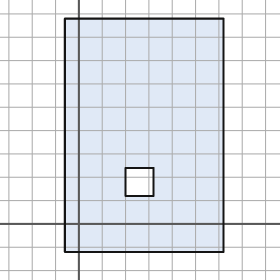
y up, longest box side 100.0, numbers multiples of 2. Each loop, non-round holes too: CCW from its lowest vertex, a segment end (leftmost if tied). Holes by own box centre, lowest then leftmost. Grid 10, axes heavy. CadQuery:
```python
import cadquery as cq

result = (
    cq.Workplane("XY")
    .moveTo(-6.0, -12.0)
    .lineTo(62.0, -12.0)
    .lineTo(62.0, 88.0)
    .lineTo(-6.0, 88.0)
    .close()
    .moveTo(20.0, 12.0)
    .lineTo(32.0, 12.0)
    .lineTo(32.0, 24.0)
    .lineTo(20.0, 24.0)
    .close()
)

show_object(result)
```